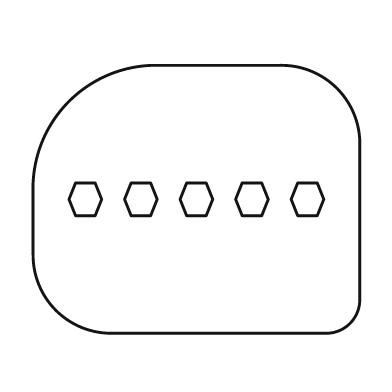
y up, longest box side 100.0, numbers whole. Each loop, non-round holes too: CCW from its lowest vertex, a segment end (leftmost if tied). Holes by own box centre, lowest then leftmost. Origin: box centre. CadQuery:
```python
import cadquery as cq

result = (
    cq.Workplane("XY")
    .moveTo(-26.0, -41.0)
    .lineTo(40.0, -41.0)
    .threePointArc((47.0, -38.0), (50.0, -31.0))
    .lineTo(50.0, 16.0)
    .threePointArc((43.0, 34.0), (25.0, 41.0))
    .lineTo(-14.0, 41.0)
    .threePointArc((-39.0, 30.0), (-50.0, 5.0))
    .lineTo(-50.0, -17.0)
    .threePointArc((-43.0, -34.0), (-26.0, -41.0))
    .close()
    .moveTo(-37.0, -5.0)
    .lineTo(-31.0, -5.0)
    .lineTo(-29.0, 0.0)
    .lineTo(-31.0, 5.0)
    .lineTo(-37.0, 5.0)
    .lineTo(-39.0, 0.0)
    .close()
    .moveTo(-20.0, -5.0)
    .lineTo(-14.0, -5.0)
    .lineTo(-12.0, 0.0)
    .lineTo(-14.0, 5.0)
    .lineTo(-20.0, 5.0)
    .lineTo(-22.0, 0.0)
    .close()
    .moveTo(-3.0, -5.0)
    .lineTo(3.0, -5.0)
    .lineTo(5.0, 0.0)
    .lineTo(3.0, 5.0)
    .lineTo(-3.0, 5.0)
    .lineTo(-5.0, 0.0)
    .close()
    .moveTo(14.0, -5.0)
    .lineTo(20.0, -5.0)
    .lineTo(22.0, 0.0)
    .lineTo(20.0, 5.0)
    .lineTo(14.0, 5.0)
    .lineTo(12.0, 0.0)
    .close()
    .moveTo(31.0, -5.0)
    .lineTo(37.0, -5.0)
    .lineTo(39.0, 0.0)
    .lineTo(37.0, 5.0)
    .lineTo(31.0, 5.0)
    .lineTo(29.0, 0.0)
    .close()
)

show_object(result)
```